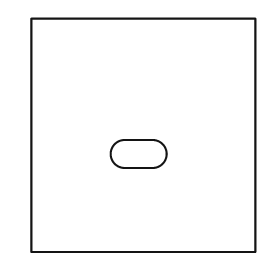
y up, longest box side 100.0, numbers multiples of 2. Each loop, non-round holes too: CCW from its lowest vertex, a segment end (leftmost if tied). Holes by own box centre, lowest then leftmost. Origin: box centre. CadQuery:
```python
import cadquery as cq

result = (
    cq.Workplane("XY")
    .moveTo(-48.0, -50.0)
    .lineTo(48.0, -50.0)
    .lineTo(48.0, 50.0)
    .lineTo(-48.0, 50.0)
    .close()
    .moveTo(-8.0, -14.0)
    .lineTo(4.0, -14.0)
    .threePointArc((10.0, -8.0), (4.0, -2.0))
    .lineTo(-8.0, -2.0)
    .threePointArc((-14.0, -8.0), (-8.0, -14.0))
    .close()
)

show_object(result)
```